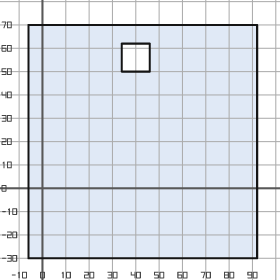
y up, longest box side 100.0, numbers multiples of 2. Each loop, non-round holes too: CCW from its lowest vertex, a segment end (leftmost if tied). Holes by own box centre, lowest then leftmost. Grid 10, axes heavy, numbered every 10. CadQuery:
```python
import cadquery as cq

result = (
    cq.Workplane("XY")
    .moveTo(-6.0, -30.0)
    .lineTo(92.0, -30.0)
    .lineTo(92.0, 70.0)
    .lineTo(-6.0, 70.0)
    .close()
    .moveTo(34.0, 50.0)
    .lineTo(46.0, 50.0)
    .lineTo(46.0, 62.0)
    .lineTo(34.0, 62.0)
    .close()
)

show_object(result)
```